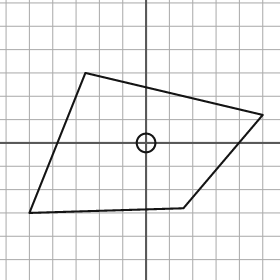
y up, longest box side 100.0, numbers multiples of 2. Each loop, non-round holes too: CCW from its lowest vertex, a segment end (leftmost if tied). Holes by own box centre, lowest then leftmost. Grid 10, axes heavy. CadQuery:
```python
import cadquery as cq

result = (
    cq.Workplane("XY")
    .moveTo(-50.0, -30.0)
    .lineTo(16.0, -28.0)
    .lineTo(50.0, 12.0)
    .lineTo(-26.0, 30.0)
    .close()
    .moveTo(0.0, 0.0)
    .circle(4.0)
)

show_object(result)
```